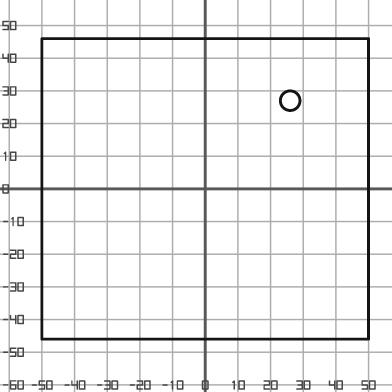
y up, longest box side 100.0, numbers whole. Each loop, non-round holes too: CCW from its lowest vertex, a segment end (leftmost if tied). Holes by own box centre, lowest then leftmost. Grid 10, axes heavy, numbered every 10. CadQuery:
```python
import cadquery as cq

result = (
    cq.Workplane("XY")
    .moveTo(-50.0, -46.0)
    .lineTo(50.0, -46.0)
    .lineTo(50.0, 46.0)
    .lineTo(-50.0, 46.0)
    .close()
    .moveTo(26.0, 27.0)
    .circle(3.0)
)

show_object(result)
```